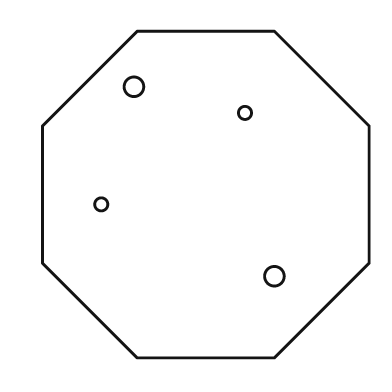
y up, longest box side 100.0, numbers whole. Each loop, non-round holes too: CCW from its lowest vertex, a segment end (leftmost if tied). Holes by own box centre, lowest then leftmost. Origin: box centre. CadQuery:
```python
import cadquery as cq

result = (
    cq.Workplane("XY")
    .moveTo(-21.0, -50.0)
    .lineTo(21.0, -50.0)
    .lineTo(50.0, -21.0)
    .lineTo(50.0, 21.0)
    .lineTo(21.0, 50.0)
    .lineTo(-21.0, 50.0)
    .lineTo(-50.0, 21.0)
    .lineTo(-50.0, -21.0)
    .close()
    .moveTo(21.0, -25.0)
    .circle(3.0)
    .moveTo(-32.0, -3.0)
    .circle(2.0)
    .moveTo(12.0, 25.0)
    .circle(2.0)
    .moveTo(-22.0, 33.0)
    .circle(3.0)
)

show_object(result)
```